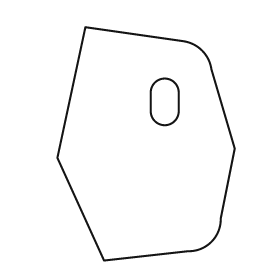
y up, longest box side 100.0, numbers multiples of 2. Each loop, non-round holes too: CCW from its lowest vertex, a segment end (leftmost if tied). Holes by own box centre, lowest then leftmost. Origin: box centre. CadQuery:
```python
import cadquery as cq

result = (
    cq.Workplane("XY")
    .moveTo(-18.0, -50.0)
    .lineTo(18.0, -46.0)
    .threePointArc((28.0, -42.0), (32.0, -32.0))
    .lineTo(38.0, -2.0)
    .lineTo(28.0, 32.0)
    .threePointArc((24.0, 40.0), (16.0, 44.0))
    .lineTo(-26.0, 50.0)
    .lineTo(-38.0, -6.0)
    .close()
    .moveTo(2.0, 14.0)
    .threePointArc((8.0, 8.0), (14.0, 14.0))
    .lineTo(14.0, 22.0)
    .threePointArc((8.0, 28.0), (2.0, 22.0))
    .close()
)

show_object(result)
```